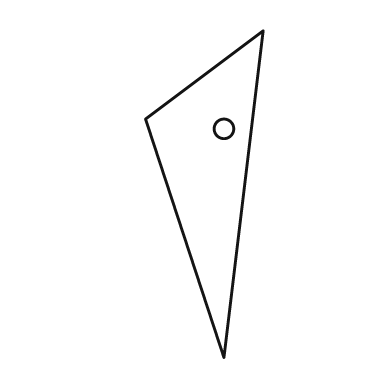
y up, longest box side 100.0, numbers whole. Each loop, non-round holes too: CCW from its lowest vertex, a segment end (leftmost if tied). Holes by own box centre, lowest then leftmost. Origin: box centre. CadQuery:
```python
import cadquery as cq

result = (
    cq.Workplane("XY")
    .moveTo(6.0, -50.0)
    .lineTo(18.0, 50.0)
    .lineTo(-18.0, 23.0)
    .close()
    .moveTo(6.0, 20.0)
    .circle(3.0)
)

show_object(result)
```